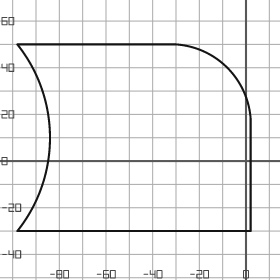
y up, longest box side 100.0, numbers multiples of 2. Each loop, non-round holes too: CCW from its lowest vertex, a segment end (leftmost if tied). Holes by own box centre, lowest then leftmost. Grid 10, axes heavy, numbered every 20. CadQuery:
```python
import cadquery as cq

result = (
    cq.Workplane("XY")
    .moveTo(-98.0, -30.0)
    .lineTo(2.0, -30.0)
    .lineTo(2.0, 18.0)
    .threePointArc((-8.0, 40.0), (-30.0, 50.0))
    .lineTo(-98.0, 50.0)
    .threePointArc((-84.0, 10.0), (-98.0, -30.0))
    .close()
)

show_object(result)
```